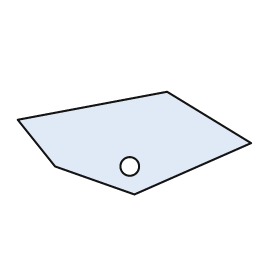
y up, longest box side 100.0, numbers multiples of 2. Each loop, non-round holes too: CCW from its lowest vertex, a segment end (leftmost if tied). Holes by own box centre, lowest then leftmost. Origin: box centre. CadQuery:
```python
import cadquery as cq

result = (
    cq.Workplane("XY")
    .moveTo(0.0, -22.0)
    .lineTo(50.0, 0.0)
    .lineTo(14.0, 22.0)
    .lineTo(-50.0, 10.0)
    .lineTo(-34.0, -10.0)
    .close()
    .moveTo(-2.0, -10.0)
    .circle(4.0)
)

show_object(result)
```